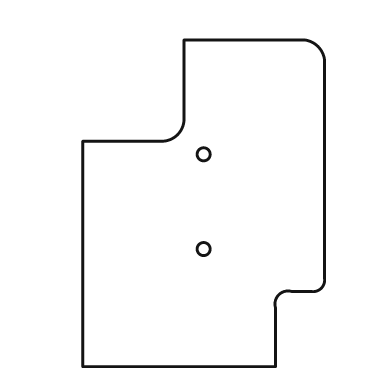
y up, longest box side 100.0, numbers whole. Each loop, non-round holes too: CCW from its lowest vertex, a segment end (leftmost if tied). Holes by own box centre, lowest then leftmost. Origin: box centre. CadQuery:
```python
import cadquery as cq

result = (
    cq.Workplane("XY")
    .moveTo(-37.0, -50.0)
    .lineTo(22.0, -50.0)
    .lineTo(22.0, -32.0)
    .threePointArc((23.0, -28.0), (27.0, -27.0))
    .lineTo(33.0, -27.0)
    .threePointArc((36.0, -26.0), (37.0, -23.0))
    .lineTo(37.0, 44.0)
    .threePointArc((35.0, 48.0), (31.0, 50.0))
    .lineTo(-6.0, 50.0)
    .lineTo(-6.0, 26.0)
    .threePointArc((-8.0, 21.0), (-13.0, 19.0))
    .lineTo(-37.0, 19.0)
    .close()
    .moveTo(0.0, -14.0)
    .circle(2.0)
    .moveTo(0.0, 15.0)
    .circle(2.0)
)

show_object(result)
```